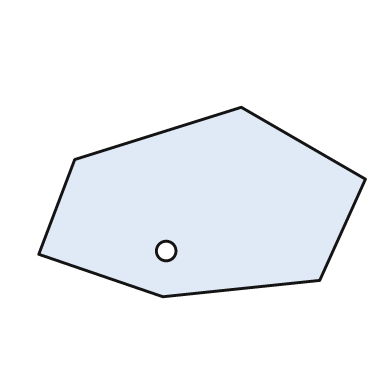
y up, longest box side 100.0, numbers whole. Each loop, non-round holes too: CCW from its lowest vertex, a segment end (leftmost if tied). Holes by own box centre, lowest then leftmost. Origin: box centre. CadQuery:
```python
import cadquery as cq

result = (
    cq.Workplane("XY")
    .moveTo(-12.0, -29.0)
    .lineTo(36.0, -24.0)
    .lineTo(50.0, 7.0)
    .lineTo(12.0, 29.0)
    .lineTo(-39.0, 13.0)
    .lineTo(-50.0, -16.0)
    .close()
    .moveTo(-11.0, -15.0)
    .circle(3.0)
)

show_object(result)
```